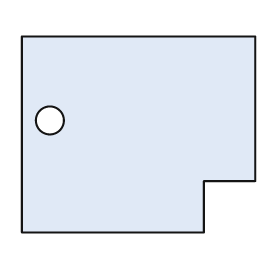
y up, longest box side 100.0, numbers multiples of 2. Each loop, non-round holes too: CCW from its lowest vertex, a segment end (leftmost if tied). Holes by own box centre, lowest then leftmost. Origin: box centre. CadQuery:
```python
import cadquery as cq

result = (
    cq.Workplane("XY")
    .moveTo(-50.0, -42.0)
    .lineTo(28.0, -42.0)
    .lineTo(28.0, -20.0)
    .lineTo(50.0, -20.0)
    .lineTo(50.0, 42.0)
    .lineTo(-50.0, 42.0)
    .close()
    .moveTo(-38.0, 6.0)
    .circle(6.0)
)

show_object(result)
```